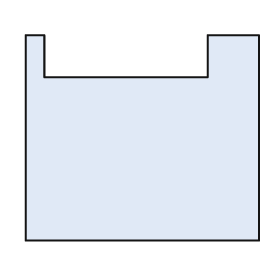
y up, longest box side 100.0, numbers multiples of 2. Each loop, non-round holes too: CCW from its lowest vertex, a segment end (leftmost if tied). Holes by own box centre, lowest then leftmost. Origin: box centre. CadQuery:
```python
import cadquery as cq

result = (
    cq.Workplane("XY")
    .moveTo(-50.0, -44.0)
    .lineTo(50.0, -44.0)
    .lineTo(50.0, 44.0)
    .lineTo(28.0, 44.0)
    .lineTo(28.0, 26.0)
    .lineTo(-42.0, 26.0)
    .lineTo(-42.0, 44.0)
    .lineTo(-50.0, 44.0)
    .close()
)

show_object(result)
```